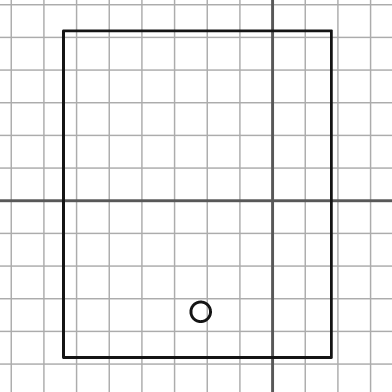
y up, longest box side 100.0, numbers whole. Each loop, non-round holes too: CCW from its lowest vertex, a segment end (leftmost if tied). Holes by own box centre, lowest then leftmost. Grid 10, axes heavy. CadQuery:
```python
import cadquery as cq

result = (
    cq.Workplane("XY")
    .moveTo(-64.0, -48.0)
    .lineTo(18.0, -48.0)
    .lineTo(18.0, 52.0)
    .lineTo(-64.0, 52.0)
    .close()
    .moveTo(-22.0, -34.0)
    .circle(3.0)
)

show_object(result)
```